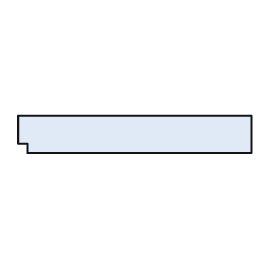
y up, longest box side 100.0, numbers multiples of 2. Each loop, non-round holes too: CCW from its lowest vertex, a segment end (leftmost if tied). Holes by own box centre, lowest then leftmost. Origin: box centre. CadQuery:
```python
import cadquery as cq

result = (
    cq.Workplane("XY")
    .moveTo(-46.0, -8.0)
    .lineTo(50.0, -8.0)
    .lineTo(50.0, 8.0)
    .lineTo(-50.0, 8.0)
    .lineTo(-50.0, -4.0)
    .lineTo(-46.0, -4.0)
    .close()
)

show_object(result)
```